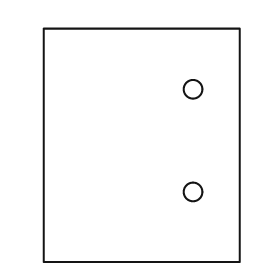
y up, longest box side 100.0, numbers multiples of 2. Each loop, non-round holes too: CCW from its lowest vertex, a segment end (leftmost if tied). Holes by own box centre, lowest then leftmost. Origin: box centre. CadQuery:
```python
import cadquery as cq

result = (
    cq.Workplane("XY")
    .moveTo(-42.0, -50.0)
    .lineTo(42.0, -50.0)
    .lineTo(42.0, 50.0)
    .lineTo(-42.0, 50.0)
    .close()
    .moveTo(22.0, -20.0)
    .circle(4.0)
    .moveTo(22.0, 24.0)
    .circle(4.0)
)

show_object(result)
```